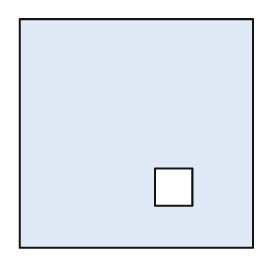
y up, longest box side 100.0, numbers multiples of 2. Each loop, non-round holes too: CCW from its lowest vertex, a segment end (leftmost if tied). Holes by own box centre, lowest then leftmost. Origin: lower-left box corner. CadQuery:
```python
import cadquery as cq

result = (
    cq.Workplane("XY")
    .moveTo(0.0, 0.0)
    .lineTo(100.0, 0.0)
    .lineTo(100.0, 98.0)
    .lineTo(0.0, 98.0)
    .close()
    .moveTo(58.0, 18.0)
    .lineTo(74.0, 18.0)
    .lineTo(74.0, 34.0)
    .lineTo(58.0, 34.0)
    .close()
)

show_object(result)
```